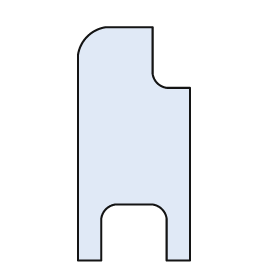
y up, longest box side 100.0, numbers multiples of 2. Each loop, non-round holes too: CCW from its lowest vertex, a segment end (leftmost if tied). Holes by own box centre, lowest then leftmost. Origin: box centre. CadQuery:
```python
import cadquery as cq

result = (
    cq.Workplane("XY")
    .moveTo(-24.0, -50.0)
    .lineTo(-14.0, -50.0)
    .lineTo(-14.0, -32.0)
    .threePointArc((-12.0, -28.0), (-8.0, -26.0))
    .lineTo(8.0, -26.0)
    .threePointArc((12.0, -28.0), (14.0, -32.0))
    .lineTo(14.0, -50.0)
    .lineTo(24.0, -50.0)
    .lineTo(24.0, 24.0)
    .lineTo(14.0, 24.0)
    .threePointArc((10.0, 26.0), (8.0, 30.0))
    .lineTo(8.0, 50.0)
    .lineTo(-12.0, 50.0)
    .threePointArc((-20.0, 46.0), (-24.0, 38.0))
    .close()
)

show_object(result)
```